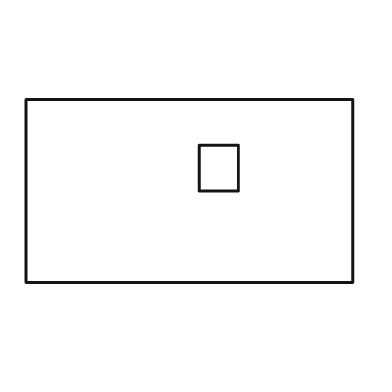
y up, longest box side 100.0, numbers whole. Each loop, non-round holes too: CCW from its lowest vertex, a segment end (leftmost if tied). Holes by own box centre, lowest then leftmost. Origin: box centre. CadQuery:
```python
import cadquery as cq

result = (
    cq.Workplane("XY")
    .moveTo(-50.0, -28.0)
    .lineTo(50.0, -28.0)
    .lineTo(50.0, 28.0)
    .lineTo(-50.0, 28.0)
    .close()
    .moveTo(3.0, 0.0)
    .lineTo(15.0, 0.0)
    .lineTo(15.0, 14.0)
    .lineTo(3.0, 14.0)
    .close()
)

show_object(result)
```